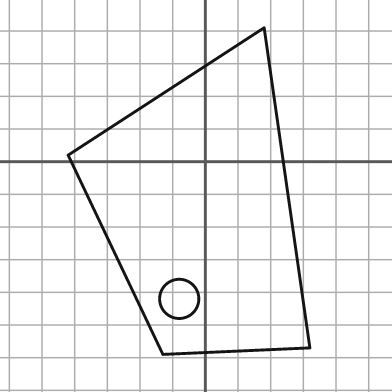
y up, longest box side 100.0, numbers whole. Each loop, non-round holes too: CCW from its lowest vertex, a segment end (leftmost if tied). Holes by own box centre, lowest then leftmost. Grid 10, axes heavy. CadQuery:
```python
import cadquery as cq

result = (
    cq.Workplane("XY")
    .moveTo(-13.0, -59.0)
    .lineTo(32.0, -57.0)
    .lineTo(18.0, 41.0)
    .lineTo(-42.0, 2.0)
    .close()
    .moveTo(-8.0, -42.0)
    .circle(6.0)
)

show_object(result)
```